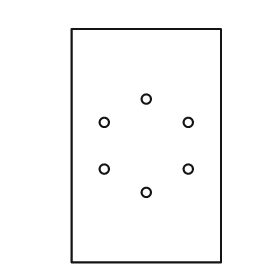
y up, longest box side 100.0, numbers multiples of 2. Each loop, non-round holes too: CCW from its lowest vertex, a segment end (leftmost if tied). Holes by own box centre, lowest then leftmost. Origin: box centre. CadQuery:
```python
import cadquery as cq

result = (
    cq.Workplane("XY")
    .moveTo(-32.0, -50.0)
    .lineTo(32.0, -50.0)
    .lineTo(32.0, 50.0)
    .lineTo(-32.0, 50.0)
    .close()
    .moveTo(0.0, -20.0)
    .circle(2.0)
    .moveTo(-18.0, -10.0)
    .circle(2.0)
    .moveTo(18.0, -10.0)
    .circle(2.0)
    .moveTo(-18.0, 10.0)
    .circle(2.0)
    .moveTo(18.0, 10.0)
    .circle(2.0)
    .moveTo(0.0, 20.0)
    .circle(2.0)
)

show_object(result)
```